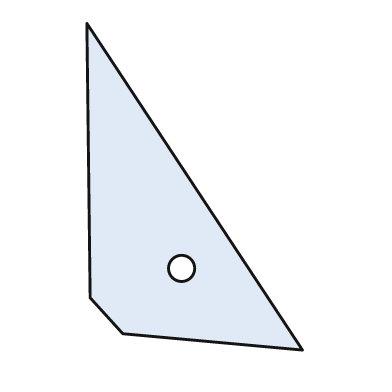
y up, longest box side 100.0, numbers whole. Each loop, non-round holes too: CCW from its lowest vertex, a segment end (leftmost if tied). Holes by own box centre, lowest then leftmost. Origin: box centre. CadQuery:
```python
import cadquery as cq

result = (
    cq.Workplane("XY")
    .moveTo(33.0, -50.0)
    .lineTo(-33.0, 50.0)
    .lineTo(-32.0, -34.0)
    .lineTo(-22.0, -45.0)
    .close()
    .moveTo(-4.0, -25.0)
    .circle(4.0)
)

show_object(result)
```